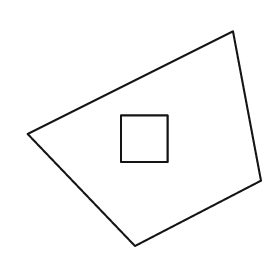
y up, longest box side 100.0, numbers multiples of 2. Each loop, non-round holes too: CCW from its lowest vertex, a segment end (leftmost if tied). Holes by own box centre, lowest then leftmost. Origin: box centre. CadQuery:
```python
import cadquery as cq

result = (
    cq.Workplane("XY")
    .moveTo(-4.0, -46.0)
    .lineTo(50.0, -18.0)
    .lineTo(38.0, 46.0)
    .lineTo(-50.0, 2.0)
    .close()
    .moveTo(-10.0, -10.0)
    .lineTo(10.0, -10.0)
    .lineTo(10.0, 10.0)
    .lineTo(-10.0, 10.0)
    .close()
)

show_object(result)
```